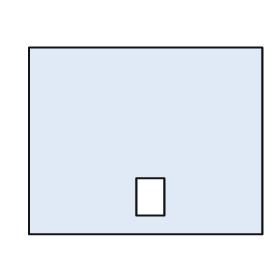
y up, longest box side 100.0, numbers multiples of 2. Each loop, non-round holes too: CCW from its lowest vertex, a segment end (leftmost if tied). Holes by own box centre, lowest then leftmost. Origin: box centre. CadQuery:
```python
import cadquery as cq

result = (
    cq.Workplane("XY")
    .moveTo(-50.0, -40.0)
    .lineTo(50.0, -40.0)
    .lineTo(50.0, 40.0)
    .lineTo(-50.0, 40.0)
    .close()
    .moveTo(-4.0, -32.0)
    .lineTo(8.0, -32.0)
    .lineTo(8.0, -16.0)
    .lineTo(-4.0, -16.0)
    .close()
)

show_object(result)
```